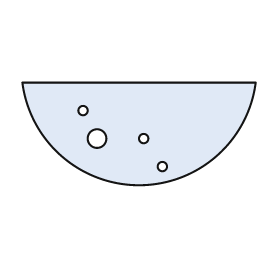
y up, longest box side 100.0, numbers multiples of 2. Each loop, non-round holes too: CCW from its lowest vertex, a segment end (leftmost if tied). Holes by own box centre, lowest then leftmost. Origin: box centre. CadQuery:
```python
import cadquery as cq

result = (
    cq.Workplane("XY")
    .moveTo(-50.0, 22.0)
    .threePointArc((0.0, -22.0), (50.0, 22.0))
    .close()
    .moveTo(10.0, -14.0)
    .circle(2.0)
    .moveTo(-18.0, -2.0)
    .circle(4.0)
    .moveTo(2.0, -2.0)
    .circle(2.0)
    .moveTo(-24.0, 10.0)
    .circle(2.0)
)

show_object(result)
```